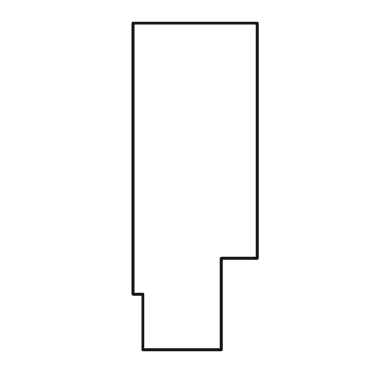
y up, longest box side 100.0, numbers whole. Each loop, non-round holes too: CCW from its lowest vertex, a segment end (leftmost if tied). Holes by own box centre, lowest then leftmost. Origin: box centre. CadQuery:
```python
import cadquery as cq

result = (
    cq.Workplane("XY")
    .moveTo(-16.0, -50.0)
    .lineTo(8.0, -50.0)
    .lineTo(8.0, -22.0)
    .lineTo(19.0, -22.0)
    .lineTo(19.0, 50.0)
    .lineTo(-19.0, 50.0)
    .lineTo(-19.0, -33.0)
    .lineTo(-16.0, -33.0)
    .close()
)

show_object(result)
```